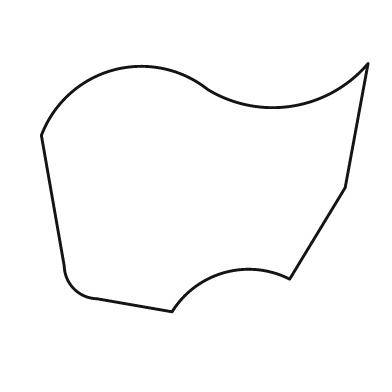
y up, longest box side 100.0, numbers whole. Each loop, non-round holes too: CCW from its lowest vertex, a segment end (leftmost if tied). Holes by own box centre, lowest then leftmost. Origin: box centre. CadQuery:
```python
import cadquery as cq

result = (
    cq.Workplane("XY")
    .moveTo(-10.0, -38.0)
    .threePointArc((6.0, -26.0), (26.0, -28.0))
    .lineTo(43.0, 0.0)
    .lineTo(50.0, 38.0)
    .threePointArc((27.0, 25.0), (1.0, 30.0))
    .threePointArc((-28.0, 36.0), (-50.0, 16.0))
    .lineTo(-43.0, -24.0)
    .threePointArc((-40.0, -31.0), (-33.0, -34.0))
    .close()
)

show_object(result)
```